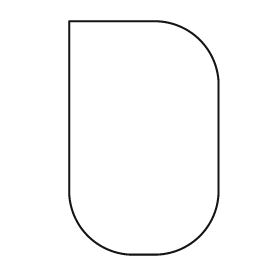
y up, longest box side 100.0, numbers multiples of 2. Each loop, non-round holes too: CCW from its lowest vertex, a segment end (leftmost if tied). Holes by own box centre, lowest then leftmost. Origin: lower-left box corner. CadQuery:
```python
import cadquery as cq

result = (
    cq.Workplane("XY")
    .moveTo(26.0, 0.0)
    .lineTo(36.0, 0.0)
    .threePointArc((56.0, 8.0), (64.0, 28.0))
    .lineTo(64.0, 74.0)
    .threePointArc((56.0, 92.0), (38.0, 100.0))
    .lineTo(0.0, 100.0)
    .lineTo(0.0, 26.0)
    .threePointArc((8.0, 8.0), (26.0, 0.0))
    .close()
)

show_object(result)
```